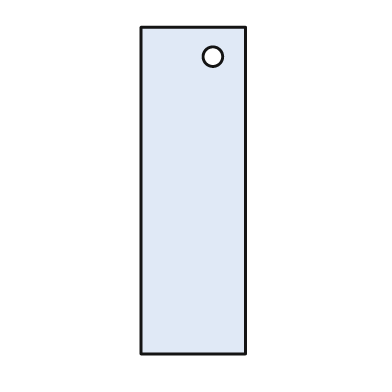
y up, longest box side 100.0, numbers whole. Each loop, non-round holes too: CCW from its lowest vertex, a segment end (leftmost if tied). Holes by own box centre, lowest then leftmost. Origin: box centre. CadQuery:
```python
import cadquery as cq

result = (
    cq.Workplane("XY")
    .moveTo(-16.0, -50.0)
    .lineTo(16.0, -50.0)
    .lineTo(16.0, 50.0)
    .lineTo(-16.0, 50.0)
    .close()
    .moveTo(6.0, 41.0)
    .circle(3.0)
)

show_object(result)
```